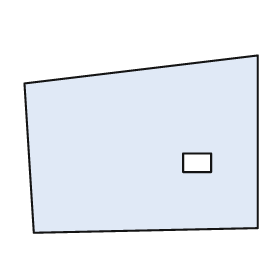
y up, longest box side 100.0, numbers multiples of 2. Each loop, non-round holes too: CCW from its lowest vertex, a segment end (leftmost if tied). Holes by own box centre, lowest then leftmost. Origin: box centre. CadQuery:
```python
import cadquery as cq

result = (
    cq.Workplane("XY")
    .moveTo(-46.0, -38.0)
    .lineTo(50.0, -36.0)
    .lineTo(50.0, 38.0)
    .lineTo(-50.0, 26.0)
    .close()
    .moveTo(18.0, -12.0)
    .lineTo(30.0, -12.0)
    .lineTo(30.0, -4.0)
    .lineTo(18.0, -4.0)
    .close()
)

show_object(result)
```